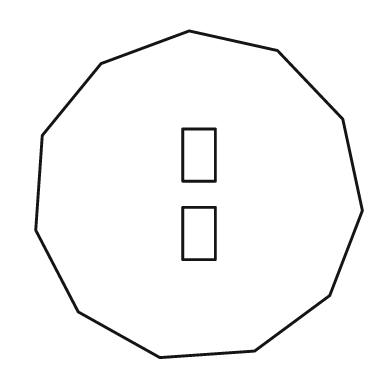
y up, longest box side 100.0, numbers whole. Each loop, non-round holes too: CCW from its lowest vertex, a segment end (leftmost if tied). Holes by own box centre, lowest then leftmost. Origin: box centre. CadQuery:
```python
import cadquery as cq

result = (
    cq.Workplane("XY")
    .moveTo(-12.0, -50.0)
    .lineTo(17.0, -48.0)
    .lineTo(40.0, -31.0)
    .lineTo(50.0, -5.0)
    .lineTo(44.0, 23.0)
    .lineTo(24.0, 44.0)
    .lineTo(-3.0, 50.0)
    .lineTo(-30.0, 40.0)
    .lineTo(-48.0, 18.0)
    .lineTo(-50.0, -11.0)
    .lineTo(-37.0, -36.0)
    .close()
    .moveTo(-5.0, -20.0)
    .lineTo(5.0, -20.0)
    .lineTo(5.0, -4.0)
    .lineTo(-5.0, -4.0)
    .close()
    .moveTo(-5.0, 4.0)
    .lineTo(5.0, 4.0)
    .lineTo(5.0, 20.0)
    .lineTo(-5.0, 20.0)
    .close()
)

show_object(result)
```